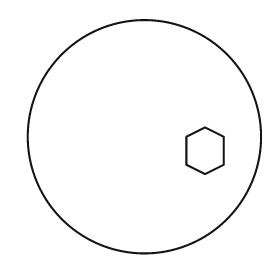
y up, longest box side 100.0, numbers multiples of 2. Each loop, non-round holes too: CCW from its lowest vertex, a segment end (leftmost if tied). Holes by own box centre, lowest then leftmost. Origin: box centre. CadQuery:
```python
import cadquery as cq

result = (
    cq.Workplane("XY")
    .moveTo(0.0, 0.0)
    .circle(50.0)
    .moveTo(26.0, -16.0)
    .lineTo(34.0, -12.0)
    .lineTo(34.0, 0.0)
    .lineTo(26.0, 4.0)
    .lineTo(18.0, 0.0)
    .lineTo(18.0, -12.0)
    .close()
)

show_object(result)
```